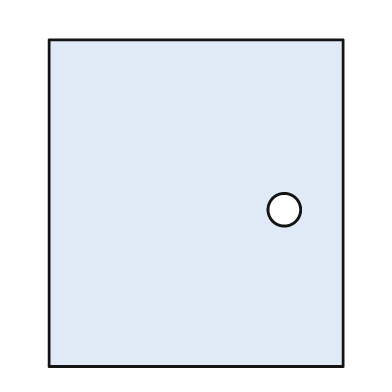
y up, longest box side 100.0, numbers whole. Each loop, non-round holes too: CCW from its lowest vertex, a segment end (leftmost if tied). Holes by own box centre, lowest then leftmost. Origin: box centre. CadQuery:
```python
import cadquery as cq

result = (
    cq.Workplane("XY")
    .moveTo(-45.0, -50.0)
    .lineTo(45.0, -50.0)
    .lineTo(45.0, 50.0)
    .lineTo(-45.0, 50.0)
    .close()
    .moveTo(27.0, -2.0)
    .circle(5.0)
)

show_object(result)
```